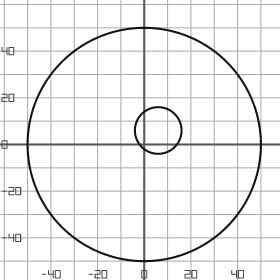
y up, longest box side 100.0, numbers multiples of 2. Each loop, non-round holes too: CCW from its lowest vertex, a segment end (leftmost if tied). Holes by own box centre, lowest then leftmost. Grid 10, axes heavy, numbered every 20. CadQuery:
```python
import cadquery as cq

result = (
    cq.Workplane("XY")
    .moveTo(0.0, 0.0)
    .circle(50.0)
    .moveTo(6.0, 6.0)
    .circle(10.0)
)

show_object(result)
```